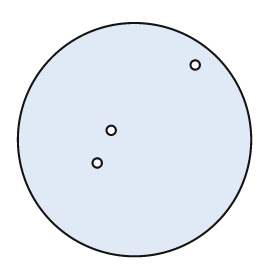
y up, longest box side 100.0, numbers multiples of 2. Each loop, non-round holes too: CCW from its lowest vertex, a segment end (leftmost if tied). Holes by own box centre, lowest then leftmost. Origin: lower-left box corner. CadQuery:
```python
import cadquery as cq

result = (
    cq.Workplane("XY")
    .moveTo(50.0, 50.0)
    .circle(50.0)
    .moveTo(34.0, 40.0)
    .circle(2.0)
    .moveTo(40.0, 54.0)
    .circle(2.0)
    .moveTo(76.0, 82.0)
    .circle(2.0)
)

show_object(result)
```